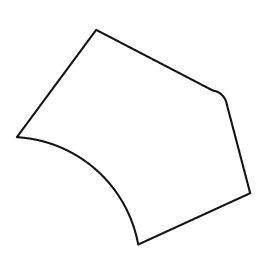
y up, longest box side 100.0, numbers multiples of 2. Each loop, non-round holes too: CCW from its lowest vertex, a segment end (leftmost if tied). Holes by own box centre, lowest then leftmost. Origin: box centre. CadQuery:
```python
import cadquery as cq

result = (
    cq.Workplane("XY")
    .moveTo(2.0, -46.0)
    .lineTo(50.0, -24.0)
    .lineTo(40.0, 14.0)
    .threePointArc((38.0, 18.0), (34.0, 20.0))
    .lineTo(-16.0, 46.0)
    .lineTo(-50.0, 0.0)
    .threePointArc((-16.0, -14.0), (2.0, -46.0))
    .close()
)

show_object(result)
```